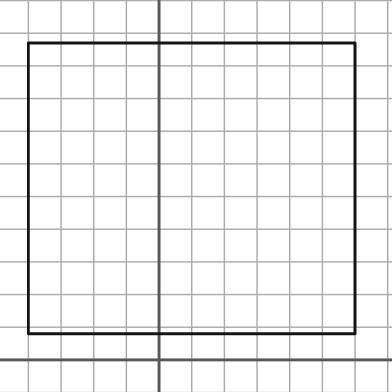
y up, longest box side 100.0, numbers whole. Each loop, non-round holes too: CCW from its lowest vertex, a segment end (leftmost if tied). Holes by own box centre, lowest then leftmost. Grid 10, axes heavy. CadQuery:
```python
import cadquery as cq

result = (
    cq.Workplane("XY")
    .moveTo(-40.0, 8.0)
    .lineTo(60.0, 8.0)
    .lineTo(60.0, 97.0)
    .lineTo(-40.0, 97.0)
    .close()
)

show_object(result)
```